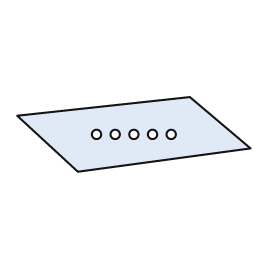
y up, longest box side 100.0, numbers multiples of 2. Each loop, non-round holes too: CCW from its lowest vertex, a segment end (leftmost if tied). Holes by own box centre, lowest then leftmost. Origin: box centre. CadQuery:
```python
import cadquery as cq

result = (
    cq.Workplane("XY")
    .moveTo(-24.0, -16.0)
    .lineTo(50.0, -6.0)
    .lineTo(24.0, 16.0)
    .lineTo(-50.0, 8.0)
    .close()
    .moveTo(-16.0, 0.0)
    .circle(2.0)
    .moveTo(-8.0, 0.0)
    .circle(2.0)
    .moveTo(0.0, 0.0)
    .circle(2.0)
    .moveTo(8.0, 0.0)
    .circle(2.0)
    .moveTo(16.0, 0.0)
    .circle(2.0)
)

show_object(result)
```